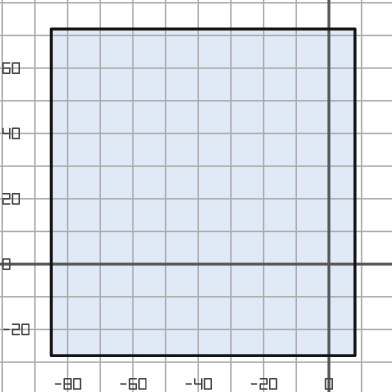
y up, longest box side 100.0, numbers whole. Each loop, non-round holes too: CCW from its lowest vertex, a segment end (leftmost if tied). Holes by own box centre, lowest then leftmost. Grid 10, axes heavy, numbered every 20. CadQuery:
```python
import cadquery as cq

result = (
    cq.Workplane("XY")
    .moveTo(-85.0, -28.0)
    .lineTo(8.0, -28.0)
    .lineTo(8.0, 72.0)
    .lineTo(-85.0, 72.0)
    .close()
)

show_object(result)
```